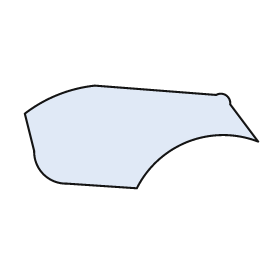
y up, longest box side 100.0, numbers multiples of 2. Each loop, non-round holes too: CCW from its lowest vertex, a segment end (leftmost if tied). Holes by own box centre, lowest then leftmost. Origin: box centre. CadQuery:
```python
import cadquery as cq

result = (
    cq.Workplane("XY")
    .moveTo(-2.0, -22.0)
    .threePointArc((20.0, -2.0), (50.0, -2.0))
    .lineTo(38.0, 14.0)
    .threePointArc((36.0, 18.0), (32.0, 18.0))
    .lineTo(-20.0, 22.0)
    .threePointArc((-36.0, 18.0), (-50.0, 10.0))
    .lineTo(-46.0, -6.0)
    .threePointArc((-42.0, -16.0), (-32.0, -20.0))
    .close()
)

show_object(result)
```